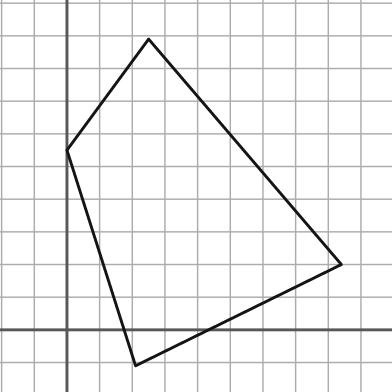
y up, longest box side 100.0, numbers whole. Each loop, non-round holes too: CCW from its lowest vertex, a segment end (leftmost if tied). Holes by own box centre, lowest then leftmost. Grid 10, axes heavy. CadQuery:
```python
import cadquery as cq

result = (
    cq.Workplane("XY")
    .moveTo(21.0, -11.0)
    .lineTo(84.0, 20.0)
    .lineTo(25.0, 89.0)
    .lineTo(0.0, 55.0)
    .close()
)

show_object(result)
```